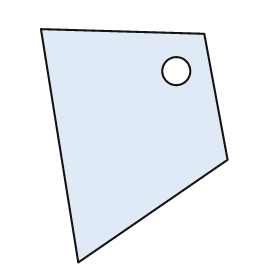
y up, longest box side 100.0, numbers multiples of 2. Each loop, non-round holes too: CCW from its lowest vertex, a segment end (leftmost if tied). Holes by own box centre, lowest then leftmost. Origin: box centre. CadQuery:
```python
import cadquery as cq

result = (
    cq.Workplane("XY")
    .moveTo(-24.0, -50.0)
    .lineTo(40.0, -6.0)
    .lineTo(30.0, 48.0)
    .lineTo(-40.0, 50.0)
    .close()
    .moveTo(18.0, 32.0)
    .circle(6.0)
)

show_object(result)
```